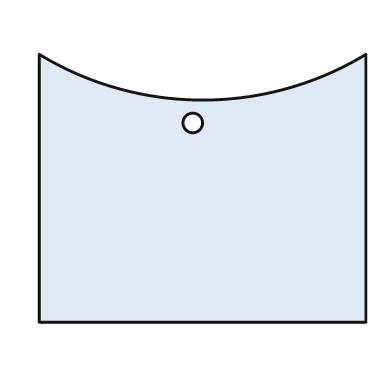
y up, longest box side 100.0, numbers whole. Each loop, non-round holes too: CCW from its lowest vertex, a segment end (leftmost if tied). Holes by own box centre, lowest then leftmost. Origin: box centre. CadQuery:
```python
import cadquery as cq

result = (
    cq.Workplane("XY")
    .moveTo(-50.0, -41.0)
    .lineTo(50.0, -41.0)
    .lineTo(50.0, 41.0)
    .threePointArc((0.0, 27.0), (-50.0, 41.0))
    .close()
    .moveTo(-3.0, 20.0)
    .circle(3.0)
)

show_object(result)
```